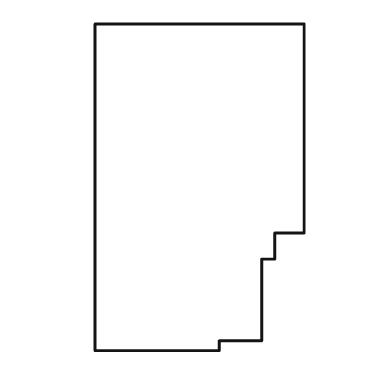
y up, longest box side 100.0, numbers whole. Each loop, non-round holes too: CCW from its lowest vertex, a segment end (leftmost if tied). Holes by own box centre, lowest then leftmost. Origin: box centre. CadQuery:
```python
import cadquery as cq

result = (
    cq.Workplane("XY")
    .moveTo(-32.0, -50.0)
    .lineTo(6.0, -50.0)
    .lineTo(6.0, -47.0)
    .lineTo(19.0, -47.0)
    .lineTo(19.0, -22.0)
    .lineTo(23.0, -22.0)
    .lineTo(23.0, -14.0)
    .lineTo(32.0, -14.0)
    .lineTo(32.0, 50.0)
    .lineTo(-32.0, 50.0)
    .close()
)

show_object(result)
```